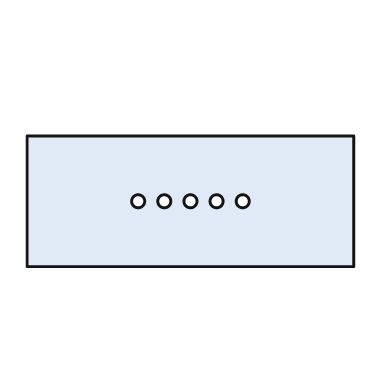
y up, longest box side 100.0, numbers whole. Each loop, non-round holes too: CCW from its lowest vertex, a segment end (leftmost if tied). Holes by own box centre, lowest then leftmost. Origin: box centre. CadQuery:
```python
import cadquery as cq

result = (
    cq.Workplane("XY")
    .moveTo(-50.0, -20.0)
    .lineTo(50.0, -20.0)
    .lineTo(50.0, 20.0)
    .lineTo(-50.0, 20.0)
    .close()
    .moveTo(-16.0, 0.0)
    .circle(2.0)
    .moveTo(-8.0, 0.0)
    .circle(2.0)
    .moveTo(0.0, 0.0)
    .circle(2.0)
    .moveTo(8.0, 0.0)
    .circle(2.0)
    .moveTo(16.0, 0.0)
    .circle(2.0)
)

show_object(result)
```